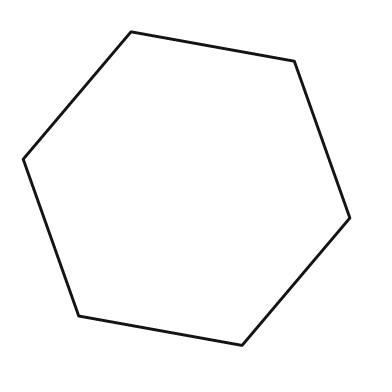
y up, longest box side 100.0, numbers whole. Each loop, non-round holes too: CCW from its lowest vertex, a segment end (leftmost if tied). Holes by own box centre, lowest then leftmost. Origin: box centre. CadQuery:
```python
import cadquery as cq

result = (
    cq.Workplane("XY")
    .moveTo(17.0, -48.0)
    .lineTo(50.0, -9.0)
    .lineTo(33.0, 39.0)
    .lineTo(-17.0, 48.0)
    .lineTo(-50.0, 9.0)
    .lineTo(-33.0, -39.0)
    .close()
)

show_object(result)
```